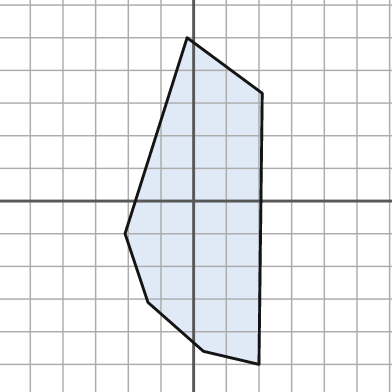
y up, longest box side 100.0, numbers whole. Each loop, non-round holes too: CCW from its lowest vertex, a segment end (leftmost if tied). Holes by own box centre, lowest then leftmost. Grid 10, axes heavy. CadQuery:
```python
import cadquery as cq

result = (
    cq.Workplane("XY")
    .moveTo(20.0, -50.0)
    .lineTo(21.0, 33.0)
    .lineTo(-2.0, 50.0)
    .lineTo(-21.0, -10.0)
    .lineTo(-14.0, -31.0)
    .lineTo(3.0, -46.0)
    .close()
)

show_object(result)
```